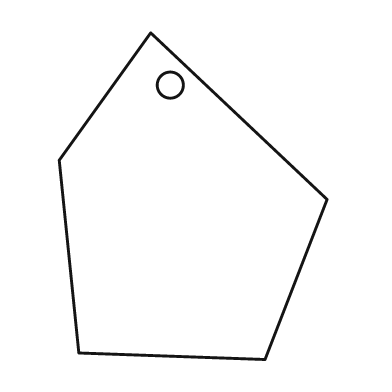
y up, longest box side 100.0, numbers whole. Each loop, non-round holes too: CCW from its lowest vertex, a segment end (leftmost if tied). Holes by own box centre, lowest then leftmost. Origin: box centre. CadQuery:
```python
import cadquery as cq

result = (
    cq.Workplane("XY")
    .moveTo(22.0, -50.0)
    .lineTo(41.0, -1.0)
    .lineTo(-13.0, 50.0)
    .lineTo(-41.0, 11.0)
    .lineTo(-35.0, -48.0)
    .close()
    .moveTo(-7.0, 34.0)
    .circle(4.0)
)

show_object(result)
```